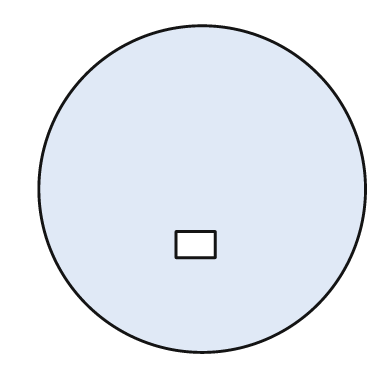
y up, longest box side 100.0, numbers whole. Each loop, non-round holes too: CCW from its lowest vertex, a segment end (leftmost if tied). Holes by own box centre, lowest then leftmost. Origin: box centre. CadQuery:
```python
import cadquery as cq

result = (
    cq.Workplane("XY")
    .moveTo(0.0, 0.0)
    .circle(50.0)
    .moveTo(-8.0, -21.0)
    .lineTo(4.0, -21.0)
    .lineTo(4.0, -13.0)
    .lineTo(-8.0, -13.0)
    .close()
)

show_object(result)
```